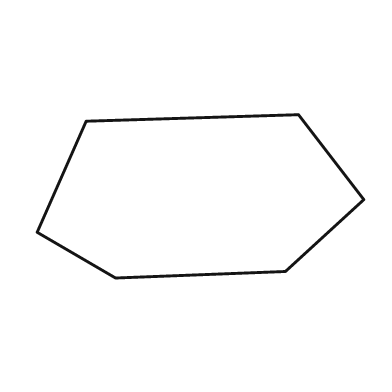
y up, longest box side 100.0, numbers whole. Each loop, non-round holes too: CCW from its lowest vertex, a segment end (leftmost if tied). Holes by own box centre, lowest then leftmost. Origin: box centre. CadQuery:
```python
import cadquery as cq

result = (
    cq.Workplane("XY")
    .moveTo(-26.0, -25.0)
    .lineTo(26.0, -23.0)
    .lineTo(50.0, -1.0)
    .lineTo(30.0, 25.0)
    .lineTo(-35.0, 23.0)
    .lineTo(-50.0, -11.0)
    .close()
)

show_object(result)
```